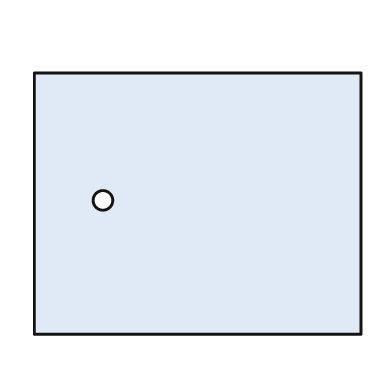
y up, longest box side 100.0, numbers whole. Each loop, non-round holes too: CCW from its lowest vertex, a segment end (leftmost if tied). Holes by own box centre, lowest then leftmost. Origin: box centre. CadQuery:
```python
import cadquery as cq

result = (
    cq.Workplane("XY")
    .moveTo(-50.0, -40.0)
    .lineTo(50.0, -40.0)
    .lineTo(50.0, 40.0)
    .lineTo(-50.0, 40.0)
    .close()
    .moveTo(-29.0, 1.0)
    .circle(3.0)
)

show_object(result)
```